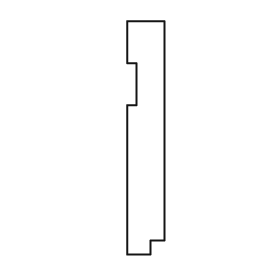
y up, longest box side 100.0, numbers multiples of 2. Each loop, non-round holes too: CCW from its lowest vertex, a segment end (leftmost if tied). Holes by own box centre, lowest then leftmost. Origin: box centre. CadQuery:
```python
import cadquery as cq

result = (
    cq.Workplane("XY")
    .moveTo(-8.0, -50.0)
    .lineTo(2.0, -50.0)
    .lineTo(2.0, -44.0)
    .lineTo(8.0, -44.0)
    .lineTo(8.0, 50.0)
    .lineTo(-8.0, 50.0)
    .lineTo(-8.0, 32.0)
    .lineTo(-4.0, 32.0)
    .lineTo(-4.0, 14.0)
    .lineTo(-8.0, 14.0)
    .close()
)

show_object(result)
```